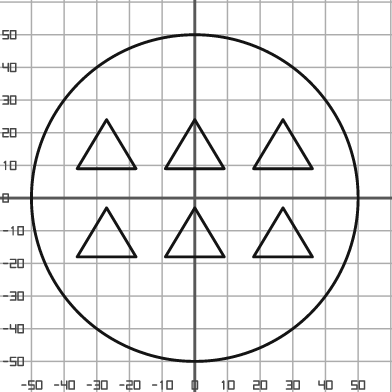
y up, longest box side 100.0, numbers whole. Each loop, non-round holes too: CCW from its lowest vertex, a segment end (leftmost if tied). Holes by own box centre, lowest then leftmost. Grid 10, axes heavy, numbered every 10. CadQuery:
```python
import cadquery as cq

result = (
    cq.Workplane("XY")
    .moveTo(0.0, 0.0)
    .circle(50.0)
    .moveTo(-36.0, -18.0)
    .lineTo(-18.0, -18.0)
    .lineTo(-27.0, -3.0)
    .close()
    .moveTo(-9.0, -18.0)
    .lineTo(9.0, -18.0)
    .lineTo(0.0, -3.0)
    .close()
    .moveTo(18.0, -18.0)
    .lineTo(36.0, -18.0)
    .lineTo(27.0, -3.0)
    .close()
    .moveTo(-36.0, 9.0)
    .lineTo(-18.0, 9.0)
    .lineTo(-27.0, 24.0)
    .close()
    .moveTo(-9.0, 9.0)
    .lineTo(9.0, 9.0)
    .lineTo(0.0, 24.0)
    .close()
    .moveTo(18.0, 9.0)
    .lineTo(36.0, 9.0)
    .lineTo(27.0, 24.0)
    .close()
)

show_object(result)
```